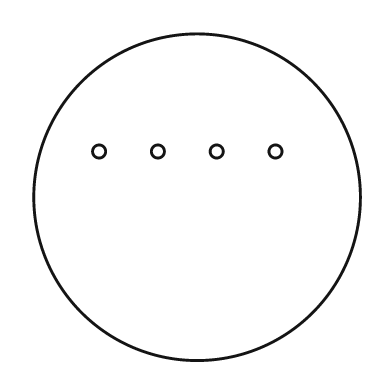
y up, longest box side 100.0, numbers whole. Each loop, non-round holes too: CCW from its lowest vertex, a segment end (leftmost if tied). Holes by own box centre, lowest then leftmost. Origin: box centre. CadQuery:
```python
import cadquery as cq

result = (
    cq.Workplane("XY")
    .moveTo(0.0, 0.0)
    .circle(50.0)
    .moveTo(-30.0, 14.0)
    .circle(2.0)
    .moveTo(-12.0, 14.0)
    .circle(2.0)
    .moveTo(6.0, 14.0)
    .circle(2.0)
    .moveTo(24.0, 14.0)
    .circle(2.0)
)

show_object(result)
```